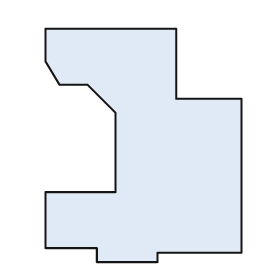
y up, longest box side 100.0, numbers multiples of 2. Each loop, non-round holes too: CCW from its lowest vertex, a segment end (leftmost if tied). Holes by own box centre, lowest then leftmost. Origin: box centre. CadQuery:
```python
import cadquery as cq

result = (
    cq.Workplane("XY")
    .moveTo(-20.0, -50.0)
    .lineTo(6.0, -50.0)
    .lineTo(6.0, -46.0)
    .lineTo(42.0, -46.0)
    .lineTo(42.0, 20.0)
    .lineTo(14.0, 20.0)
    .lineTo(14.0, 50.0)
    .lineTo(-42.0, 50.0)
    .lineTo(-42.0, 36.0)
    .lineTo(-36.0, 26.0)
    .lineTo(-24.0, 26.0)
    .lineTo(-12.0, 14.0)
    .lineTo(-12.0, -20.0)
    .lineTo(-42.0, -20.0)
    .lineTo(-42.0, -44.0)
    .lineTo(-20.0, -44.0)
    .close()
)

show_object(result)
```